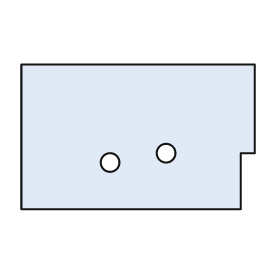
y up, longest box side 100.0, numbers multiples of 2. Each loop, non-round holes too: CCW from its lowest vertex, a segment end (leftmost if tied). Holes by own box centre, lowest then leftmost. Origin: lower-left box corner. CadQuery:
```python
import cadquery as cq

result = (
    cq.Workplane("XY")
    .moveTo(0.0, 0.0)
    .lineTo(94.0, 0.0)
    .lineTo(94.0, 24.0)
    .lineTo(100.0, 24.0)
    .lineTo(100.0, 62.0)
    .lineTo(0.0, 62.0)
    .close()
    .moveTo(38.0, 20.0)
    .circle(4.0)
    .moveTo(62.0, 24.0)
    .circle(4.0)
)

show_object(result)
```